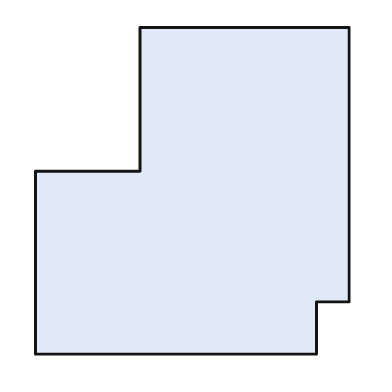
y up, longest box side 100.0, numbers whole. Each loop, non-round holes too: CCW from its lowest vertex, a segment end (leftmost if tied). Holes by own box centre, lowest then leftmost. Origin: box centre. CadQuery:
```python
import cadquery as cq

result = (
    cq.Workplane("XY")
    .moveTo(-48.0, -50.0)
    .lineTo(38.0, -50.0)
    .lineTo(38.0, -34.0)
    .lineTo(48.0, -34.0)
    .lineTo(48.0, 50.0)
    .lineTo(-16.0, 50.0)
    .lineTo(-16.0, 6.0)
    .lineTo(-48.0, 6.0)
    .close()
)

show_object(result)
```